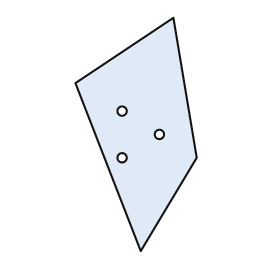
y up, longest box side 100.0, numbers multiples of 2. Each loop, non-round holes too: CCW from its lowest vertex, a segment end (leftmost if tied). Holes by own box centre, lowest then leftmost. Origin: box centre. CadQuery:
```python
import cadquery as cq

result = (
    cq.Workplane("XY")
    .moveTo(2.0, -50.0)
    .lineTo(26.0, -10.0)
    .lineTo(16.0, 50.0)
    .lineTo(-26.0, 22.0)
    .close()
    .moveTo(-6.0, -10.0)
    .circle(2.0)
    .moveTo(10.0, 0.0)
    .circle(2.0)
    .moveTo(-6.0, 10.0)
    .circle(2.0)
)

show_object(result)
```